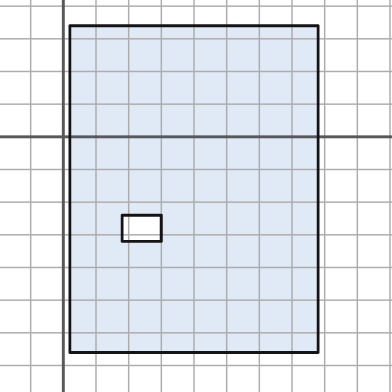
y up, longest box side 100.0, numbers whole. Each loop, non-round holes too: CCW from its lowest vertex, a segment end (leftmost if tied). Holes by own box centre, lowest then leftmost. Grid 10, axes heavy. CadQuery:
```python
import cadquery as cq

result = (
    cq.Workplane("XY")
    .moveTo(2.0, -66.0)
    .lineTo(78.0, -66.0)
    .lineTo(78.0, 34.0)
    .lineTo(2.0, 34.0)
    .close()
    .moveTo(18.0, -32.0)
    .lineTo(30.0, -32.0)
    .lineTo(30.0, -24.0)
    .lineTo(18.0, -24.0)
    .close()
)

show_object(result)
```